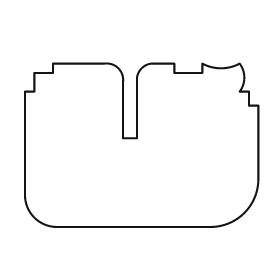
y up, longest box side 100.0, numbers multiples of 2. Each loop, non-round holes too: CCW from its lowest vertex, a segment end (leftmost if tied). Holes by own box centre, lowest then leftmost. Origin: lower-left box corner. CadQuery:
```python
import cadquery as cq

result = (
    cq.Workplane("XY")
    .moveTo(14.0, 0.0)
    .lineTo(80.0, 0.0)
    .threePointArc((94.0, 6.0), (100.0, 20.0))
    .lineTo(100.0, 52.0)
    .lineTo(96.0, 52.0)
    .lineTo(96.0, 58.0)
    .lineTo(92.0, 58.0)
    .threePointArc((94.0, 64.0), (92.0, 70.0))
    .threePointArc((84.0, 68.0), (76.0, 70.0))
    .lineTo(76.0, 66.0)
    .lineTo(64.0, 66.0)
    .lineTo(64.0, 70.0)
    .lineTo(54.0, 70.0)
    .threePointArc((50.0, 68.0), (48.0, 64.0))
    .lineTo(48.0, 38.0)
    .lineTo(42.0, 38.0)
    .lineTo(42.0, 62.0)
    .threePointArc((40.0, 68.0), (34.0, 70.0))
    .lineTo(12.0, 70.0)
    .lineTo(12.0, 66.0)
    .lineTo(4.0, 66.0)
    .lineTo(4.0, 58.0)
    .lineTo(0.0, 58.0)
    .lineTo(0.0, 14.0)
    .threePointArc((4.0, 4.0), (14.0, 0.0))
    .close()
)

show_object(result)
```